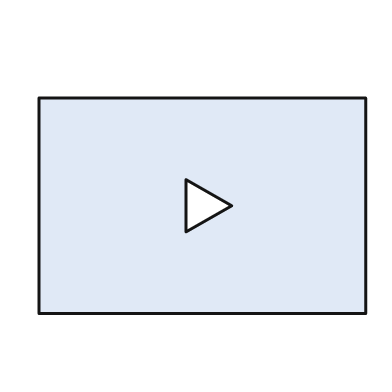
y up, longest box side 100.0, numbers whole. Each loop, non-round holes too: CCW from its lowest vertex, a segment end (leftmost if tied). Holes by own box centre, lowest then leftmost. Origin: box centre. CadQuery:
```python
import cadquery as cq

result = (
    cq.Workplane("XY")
    .moveTo(-50.0, -33.0)
    .lineTo(50.0, -33.0)
    .lineTo(50.0, 33.0)
    .lineTo(-50.0, 33.0)
    .close()
    .moveTo(-5.0, -8.0)
    .lineTo(9.0, 0.0)
    .lineTo(-5.0, 8.0)
    .close()
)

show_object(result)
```